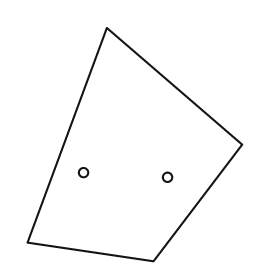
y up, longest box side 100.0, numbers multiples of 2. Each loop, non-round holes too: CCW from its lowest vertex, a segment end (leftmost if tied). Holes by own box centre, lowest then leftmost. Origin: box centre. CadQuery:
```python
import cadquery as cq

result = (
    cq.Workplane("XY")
    .moveTo(8.0, -50.0)
    .lineTo(46.0, 0.0)
    .lineTo(-12.0, 50.0)
    .lineTo(-46.0, -42.0)
    .close()
    .moveTo(14.0, -14.0)
    .circle(2.0)
    .moveTo(-22.0, -12.0)
    .circle(2.0)
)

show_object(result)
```